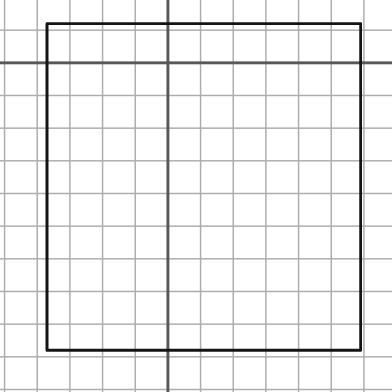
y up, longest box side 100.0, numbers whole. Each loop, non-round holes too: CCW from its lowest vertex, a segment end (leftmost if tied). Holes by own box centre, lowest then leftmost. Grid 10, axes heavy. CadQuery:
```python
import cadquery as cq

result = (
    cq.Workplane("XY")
    .moveTo(-37.0, -88.0)
    .lineTo(59.0, -88.0)
    .lineTo(59.0, 12.0)
    .lineTo(-37.0, 12.0)
    .close()
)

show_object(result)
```